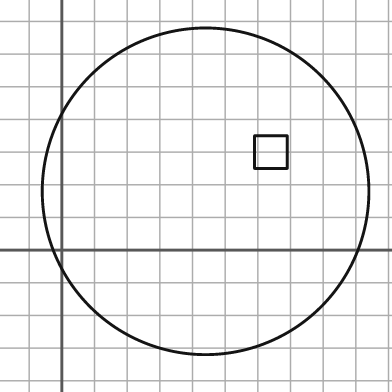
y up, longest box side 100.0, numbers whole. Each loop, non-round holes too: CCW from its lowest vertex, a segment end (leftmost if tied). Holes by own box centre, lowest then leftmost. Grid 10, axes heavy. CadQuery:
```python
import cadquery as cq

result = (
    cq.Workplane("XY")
    .moveTo(44.0, 18.0)
    .circle(50.0)
    .moveTo(59.0, 25.0)
    .lineTo(69.0, 25.0)
    .lineTo(69.0, 35.0)
    .lineTo(59.0, 35.0)
    .close()
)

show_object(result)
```